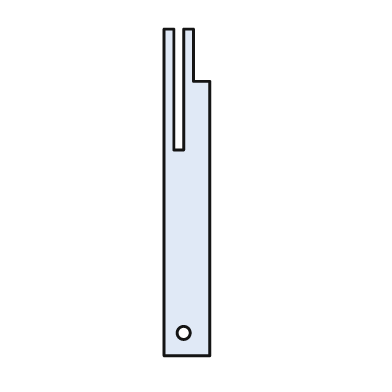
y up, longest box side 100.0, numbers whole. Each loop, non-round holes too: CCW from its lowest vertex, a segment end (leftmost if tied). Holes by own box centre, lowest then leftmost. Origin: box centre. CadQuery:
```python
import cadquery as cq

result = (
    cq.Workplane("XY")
    .moveTo(-7.0, -50.0)
    .lineTo(7.0, -50.0)
    .lineTo(7.0, 34.0)
    .lineTo(2.0, 34.0)
    .lineTo(2.0, 50.0)
    .lineTo(-1.0, 50.0)
    .lineTo(-1.0, 13.0)
    .lineTo(-4.0, 13.0)
    .lineTo(-4.0, 50.0)
    .lineTo(-7.0, 50.0)
    .close()
    .moveTo(-1.0, -43.0)
    .circle(2.0)
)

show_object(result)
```